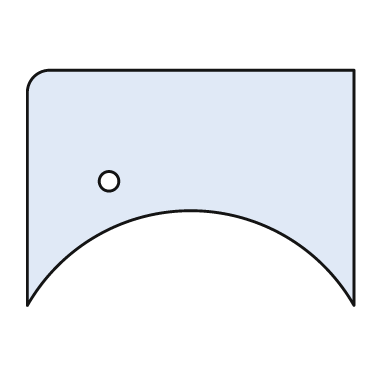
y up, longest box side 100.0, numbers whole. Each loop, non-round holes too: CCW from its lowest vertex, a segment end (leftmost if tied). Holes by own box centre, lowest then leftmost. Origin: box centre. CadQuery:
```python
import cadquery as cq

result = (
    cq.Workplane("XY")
    .moveTo(-50.0, -36.0)
    .threePointArc((0.0, -7.0), (50.0, -36.0))
    .lineTo(50.0, 36.0)
    .lineTo(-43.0, 36.0)
    .threePointArc((-48.0, 34.0), (-50.0, 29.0))
    .close()
    .moveTo(-25.0, 2.0)
    .circle(3.0)
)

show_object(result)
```